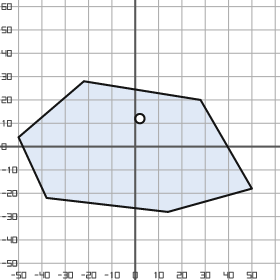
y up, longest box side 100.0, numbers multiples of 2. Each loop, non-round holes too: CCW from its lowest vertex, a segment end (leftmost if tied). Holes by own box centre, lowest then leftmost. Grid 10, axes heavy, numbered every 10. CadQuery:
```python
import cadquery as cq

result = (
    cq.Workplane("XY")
    .moveTo(14.0, -28.0)
    .lineTo(50.0, -18.0)
    .lineTo(28.0, 20.0)
    .lineTo(-22.0, 28.0)
    .lineTo(-50.0, 4.0)
    .lineTo(-38.0, -22.0)
    .close()
    .moveTo(2.0, 12.0)
    .circle(2.0)
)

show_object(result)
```